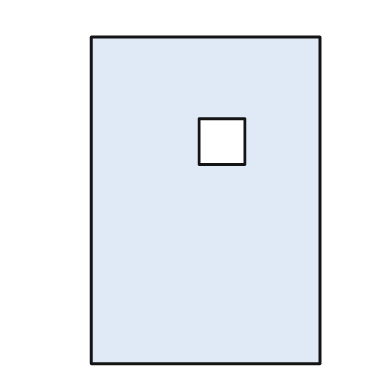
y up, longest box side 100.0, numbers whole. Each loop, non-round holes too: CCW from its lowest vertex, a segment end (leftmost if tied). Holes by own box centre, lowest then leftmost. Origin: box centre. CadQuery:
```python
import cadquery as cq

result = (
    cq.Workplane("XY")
    .moveTo(-35.0, -50.0)
    .lineTo(35.0, -50.0)
    .lineTo(35.0, 50.0)
    .lineTo(-35.0, 50.0)
    .close()
    .moveTo(-2.0, 11.0)
    .lineTo(12.0, 11.0)
    .lineTo(12.0, 25.0)
    .lineTo(-2.0, 25.0)
    .close()
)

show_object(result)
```